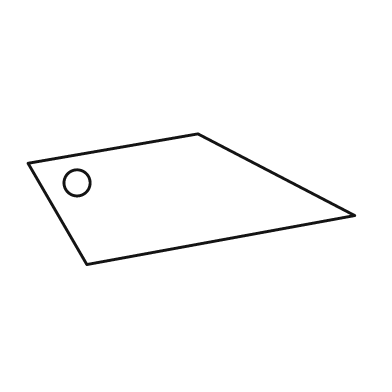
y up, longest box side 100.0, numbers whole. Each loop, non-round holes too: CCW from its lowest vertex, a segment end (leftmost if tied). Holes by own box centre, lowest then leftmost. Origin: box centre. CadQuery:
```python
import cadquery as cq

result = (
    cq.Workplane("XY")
    .moveTo(-32.0, -20.0)
    .lineTo(50.0, -5.0)
    .lineTo(2.0, 20.0)
    .lineTo(-50.0, 11.0)
    .close()
    .moveTo(-35.0, 5.0)
    .circle(4.0)
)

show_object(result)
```